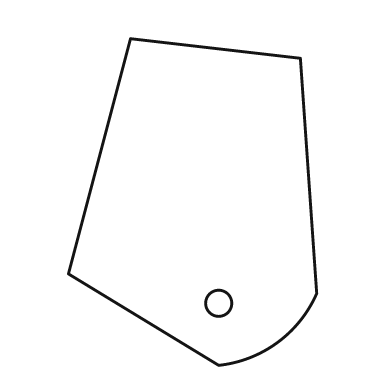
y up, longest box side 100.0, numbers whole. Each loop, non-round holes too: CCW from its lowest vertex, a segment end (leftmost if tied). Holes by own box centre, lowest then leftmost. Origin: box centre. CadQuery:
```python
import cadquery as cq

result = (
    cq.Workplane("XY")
    .moveTo(8.0, -50.0)
    .threePointArc((26.0, -43.0), (38.0, -28.0))
    .lineTo(33.0, 44.0)
    .lineTo(-19.0, 50.0)
    .lineTo(-38.0, -22.0)
    .close()
    .moveTo(8.0, -31.0)
    .circle(4.0)
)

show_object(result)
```